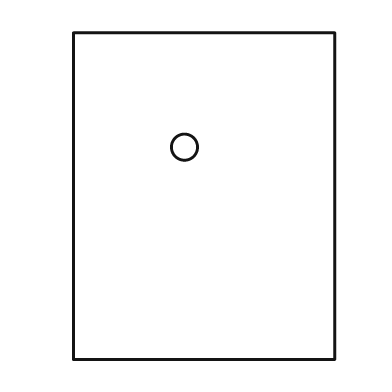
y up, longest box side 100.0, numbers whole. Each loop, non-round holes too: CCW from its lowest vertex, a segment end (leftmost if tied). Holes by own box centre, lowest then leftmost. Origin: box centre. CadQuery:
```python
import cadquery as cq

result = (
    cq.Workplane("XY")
    .moveTo(-40.0, -50.0)
    .lineTo(40.0, -50.0)
    .lineTo(40.0, 50.0)
    .lineTo(-40.0, 50.0)
    .close()
    .moveTo(-6.0, 15.0)
    .circle(4.0)
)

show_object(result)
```